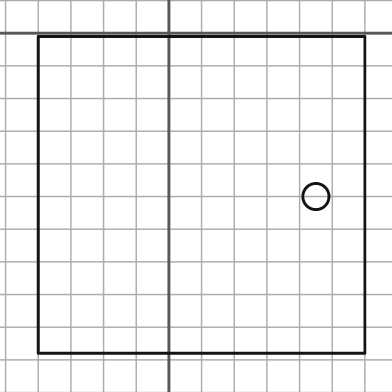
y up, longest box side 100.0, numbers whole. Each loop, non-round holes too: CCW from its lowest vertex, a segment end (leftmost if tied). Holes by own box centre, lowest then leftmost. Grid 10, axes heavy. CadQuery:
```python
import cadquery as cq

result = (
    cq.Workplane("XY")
    .moveTo(-40.0, -98.0)
    .lineTo(60.0, -98.0)
    .lineTo(60.0, -1.0)
    .lineTo(-40.0, -1.0)
    .close()
    .moveTo(45.0, -50.0)
    .circle(4.0)
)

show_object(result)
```